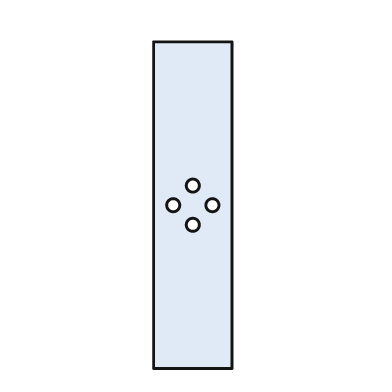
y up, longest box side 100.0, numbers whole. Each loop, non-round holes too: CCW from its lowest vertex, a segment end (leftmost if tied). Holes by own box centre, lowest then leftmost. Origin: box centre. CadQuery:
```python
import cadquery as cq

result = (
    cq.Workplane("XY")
    .moveTo(-12.0, -50.0)
    .lineTo(12.0, -50.0)
    .lineTo(12.0, 50.0)
    .lineTo(-12.0, 50.0)
    .close()
    .moveTo(0.0, -6.0)
    .circle(2.0)
    .moveTo(-6.0, 0.0)
    .circle(2.0)
    .moveTo(6.0, 0.0)
    .circle(2.0)
    .moveTo(0.0, 6.0)
    .circle(2.0)
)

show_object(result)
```